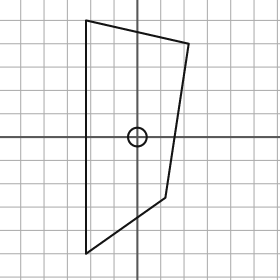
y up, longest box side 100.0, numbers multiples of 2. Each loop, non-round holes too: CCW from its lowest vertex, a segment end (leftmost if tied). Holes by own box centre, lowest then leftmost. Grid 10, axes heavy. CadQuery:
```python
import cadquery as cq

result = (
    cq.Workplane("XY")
    .moveTo(-22.0, -50.0)
    .lineTo(12.0, -26.0)
    .lineTo(22.0, 40.0)
    .lineTo(-22.0, 50.0)
    .close()
    .moveTo(0.0, 0.0)
    .circle(4.0)
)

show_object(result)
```